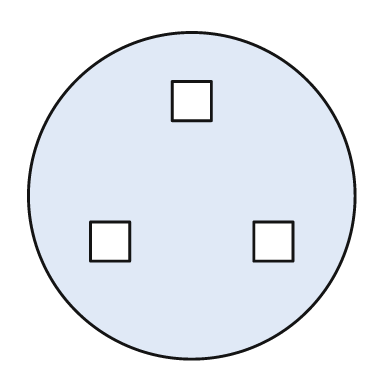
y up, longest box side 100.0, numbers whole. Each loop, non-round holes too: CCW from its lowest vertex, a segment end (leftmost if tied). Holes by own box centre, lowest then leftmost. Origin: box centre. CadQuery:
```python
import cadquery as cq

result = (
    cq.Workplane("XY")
    .moveTo(0.0, 0.0)
    .circle(50.0)
    .moveTo(-31.0, -20.0)
    .lineTo(-19.0, -20.0)
    .lineTo(-19.0, -8.0)
    .lineTo(-31.0, -8.0)
    .close()
    .moveTo(19.0, -20.0)
    .lineTo(31.0, -20.0)
    .lineTo(31.0, -8.0)
    .lineTo(19.0, -8.0)
    .close()
    .moveTo(-6.0, 23.0)
    .lineTo(6.0, 23.0)
    .lineTo(6.0, 35.0)
    .lineTo(-6.0, 35.0)
    .close()
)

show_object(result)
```